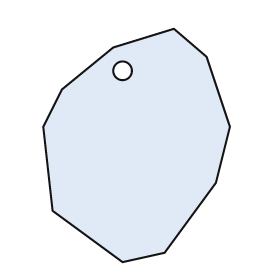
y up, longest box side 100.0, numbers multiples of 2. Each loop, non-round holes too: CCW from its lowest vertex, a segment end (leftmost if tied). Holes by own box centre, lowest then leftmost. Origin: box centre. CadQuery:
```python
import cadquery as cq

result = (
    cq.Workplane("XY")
    .moveTo(-6.0, -50.0)
    .lineTo(12.0, -46.0)
    .lineTo(34.0, -16.0)
    .lineTo(40.0, 8.0)
    .lineTo(30.0, 38.0)
    .lineTo(16.0, 50.0)
    .lineTo(-10.0, 42.0)
    .lineTo(-32.0, 24.0)
    .lineTo(-40.0, 8.0)
    .lineTo(-36.0, -28.0)
    .close()
    .moveTo(-6.0, 32.0)
    .circle(4.0)
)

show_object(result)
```